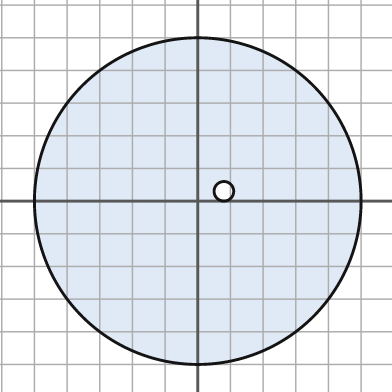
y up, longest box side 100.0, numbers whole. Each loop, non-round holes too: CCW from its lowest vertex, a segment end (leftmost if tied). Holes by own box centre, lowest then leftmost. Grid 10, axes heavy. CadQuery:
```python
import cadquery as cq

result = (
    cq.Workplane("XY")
    .moveTo(0.0, 0.0)
    .circle(50.0)
    .moveTo(8.0, 3.0)
    .circle(3.0)
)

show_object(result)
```